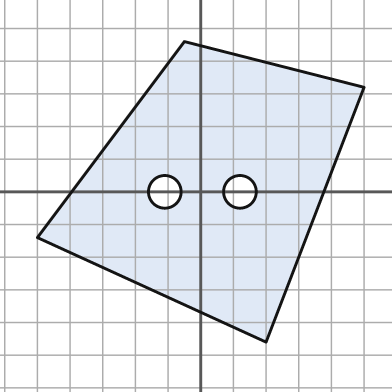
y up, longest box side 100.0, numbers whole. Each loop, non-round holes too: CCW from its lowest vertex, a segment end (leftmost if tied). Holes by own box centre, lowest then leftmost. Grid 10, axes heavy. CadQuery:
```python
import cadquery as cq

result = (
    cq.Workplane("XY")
    .moveTo(20.0, -46.0)
    .lineTo(50.0, 32.0)
    .lineTo(-5.0, 46.0)
    .lineTo(-50.0, -14.0)
    .close()
    .moveTo(-11.0, 0.0)
    .circle(5.0)
    .moveTo(12.0, 0.0)
    .circle(5.0)
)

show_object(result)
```